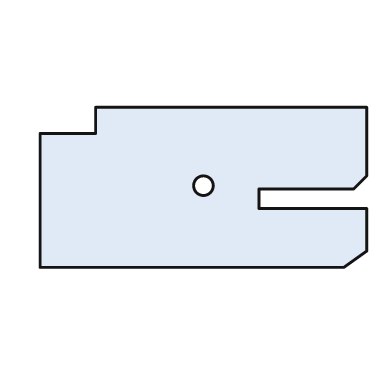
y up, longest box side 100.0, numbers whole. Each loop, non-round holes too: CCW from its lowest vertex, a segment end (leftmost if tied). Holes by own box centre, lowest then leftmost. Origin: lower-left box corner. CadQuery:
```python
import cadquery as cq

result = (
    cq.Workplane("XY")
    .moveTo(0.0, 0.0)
    .lineTo(93.0, 0.0)
    .lineTo(100.0, 5.0)
    .lineTo(100.0, 18.0)
    .lineTo(67.0, 18.0)
    .lineTo(67.0, 24.0)
    .lineTo(96.0, 24.0)
    .lineTo(100.0, 28.0)
    .lineTo(100.0, 49.0)
    .lineTo(17.0, 49.0)
    .lineTo(17.0, 41.0)
    .lineTo(0.0, 41.0)
    .close()
    .moveTo(50.0, 25.0)
    .circle(3.0)
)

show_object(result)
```